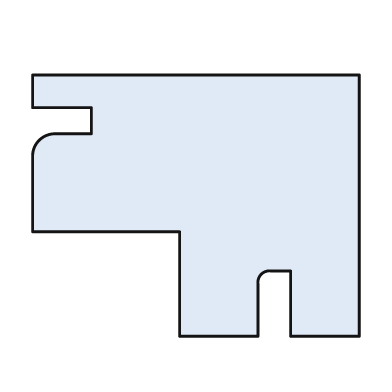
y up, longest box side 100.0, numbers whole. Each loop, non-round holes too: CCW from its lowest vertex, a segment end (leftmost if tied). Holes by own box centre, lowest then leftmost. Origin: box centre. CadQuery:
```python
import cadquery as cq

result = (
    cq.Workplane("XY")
    .moveTo(-5.0, -40.0)
    .lineTo(19.0, -40.0)
    .lineTo(19.0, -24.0)
    .threePointArc((20.0, -21.0), (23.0, -20.0))
    .lineTo(29.0, -20.0)
    .lineTo(29.0, -40.0)
    .lineTo(50.0, -40.0)
    .lineTo(50.0, 40.0)
    .lineTo(-50.0, 40.0)
    .lineTo(-50.0, 30.0)
    .lineTo(-32.0, 30.0)
    .lineTo(-32.0, 22.0)
    .lineTo(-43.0, 22.0)
    .threePointArc((-48.0, 20.0), (-50.0, 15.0))
    .lineTo(-50.0, -8.0)
    .lineTo(-5.0, -8.0)
    .close()
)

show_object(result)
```